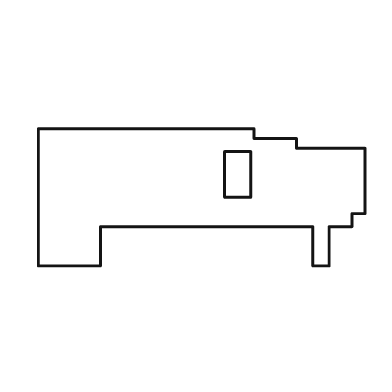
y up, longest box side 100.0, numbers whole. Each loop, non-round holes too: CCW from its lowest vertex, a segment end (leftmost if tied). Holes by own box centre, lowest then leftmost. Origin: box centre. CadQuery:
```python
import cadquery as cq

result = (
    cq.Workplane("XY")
    .moveTo(-50.0, -21.0)
    .lineTo(-31.0, -21.0)
    .lineTo(-31.0, -9.0)
    .lineTo(34.0, -9.0)
    .lineTo(34.0, -21.0)
    .lineTo(39.0, -21.0)
    .lineTo(39.0, -9.0)
    .lineTo(46.0, -9.0)
    .lineTo(46.0, -5.0)
    .lineTo(50.0, -5.0)
    .lineTo(50.0, 15.0)
    .lineTo(29.0, 15.0)
    .lineTo(29.0, 18.0)
    .lineTo(16.0, 18.0)
    .lineTo(16.0, 21.0)
    .lineTo(-50.0, 21.0)
    .close()
    .moveTo(7.0, 0.0)
    .lineTo(15.0, 0.0)
    .lineTo(15.0, 14.0)
    .lineTo(7.0, 14.0)
    .close()
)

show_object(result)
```